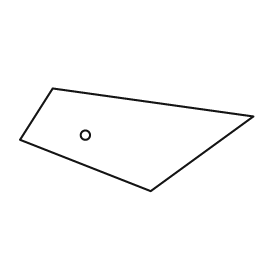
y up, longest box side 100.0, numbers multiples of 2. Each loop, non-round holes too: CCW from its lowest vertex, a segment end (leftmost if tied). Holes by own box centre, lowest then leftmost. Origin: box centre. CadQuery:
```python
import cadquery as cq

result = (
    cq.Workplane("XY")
    .moveTo(6.0, -22.0)
    .lineTo(50.0, 10.0)
    .lineTo(-36.0, 22.0)
    .lineTo(-50.0, 0.0)
    .close()
    .moveTo(-22.0, 2.0)
    .circle(2.0)
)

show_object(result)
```